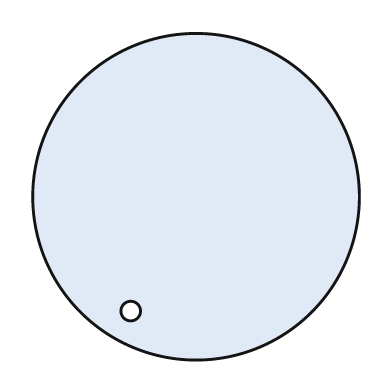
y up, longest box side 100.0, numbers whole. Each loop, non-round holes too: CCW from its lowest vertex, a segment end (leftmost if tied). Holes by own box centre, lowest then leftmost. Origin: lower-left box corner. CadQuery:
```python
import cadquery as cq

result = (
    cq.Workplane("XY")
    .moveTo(50.0, 50.0)
    .circle(50.0)
    .moveTo(30.0, 15.0)
    .circle(3.0)
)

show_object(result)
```